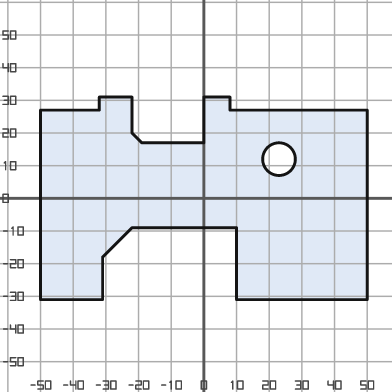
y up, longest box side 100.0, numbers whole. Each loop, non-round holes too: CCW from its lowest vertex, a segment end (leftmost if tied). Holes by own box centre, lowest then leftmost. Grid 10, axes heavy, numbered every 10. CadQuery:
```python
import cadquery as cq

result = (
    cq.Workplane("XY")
    .moveTo(-50.0, -31.0)
    .lineTo(-31.0, -31.0)
    .lineTo(-31.0, -18.0)
    .lineTo(-22.0, -9.0)
    .lineTo(10.0, -9.0)
    .lineTo(10.0, -31.0)
    .lineTo(50.0, -31.0)
    .lineTo(50.0, 27.0)
    .lineTo(8.0, 27.0)
    .lineTo(8.0, 31.0)
    .lineTo(0.0, 31.0)
    .lineTo(0.0, 17.0)
    .lineTo(-19.0, 17.0)
    .lineTo(-22.0, 20.0)
    .lineTo(-22.0, 31.0)
    .lineTo(-32.0, 31.0)
    .lineTo(-32.0, 27.0)
    .lineTo(-50.0, 27.0)
    .close()
    .moveTo(23.0, 12.0)
    .circle(5.0)
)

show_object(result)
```